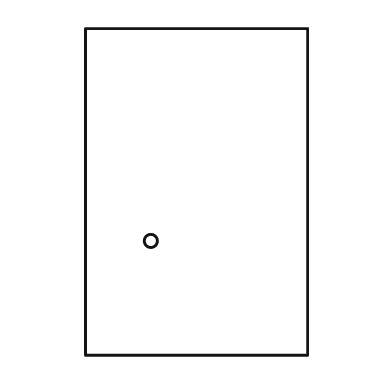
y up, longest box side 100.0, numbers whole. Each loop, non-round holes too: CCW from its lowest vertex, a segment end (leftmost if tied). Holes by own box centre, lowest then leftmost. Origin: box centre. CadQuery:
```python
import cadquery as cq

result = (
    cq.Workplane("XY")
    .moveTo(-34.0, -50.0)
    .lineTo(34.0, -50.0)
    .lineTo(34.0, 50.0)
    .lineTo(-34.0, 50.0)
    .close()
    .moveTo(-14.0, -15.0)
    .circle(2.0)
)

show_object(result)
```